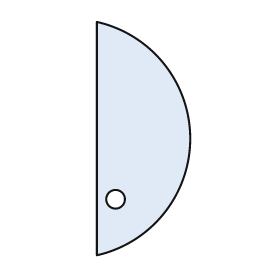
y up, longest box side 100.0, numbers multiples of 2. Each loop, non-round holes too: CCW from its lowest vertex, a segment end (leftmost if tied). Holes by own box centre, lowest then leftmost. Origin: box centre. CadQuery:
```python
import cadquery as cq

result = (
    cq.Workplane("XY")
    .moveTo(-20.0, -50.0)
    .threePointArc((20.0, 0.0), (-20.0, 50.0))
    .close()
    .moveTo(-12.0, -26.0)
    .circle(4.0)
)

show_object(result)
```